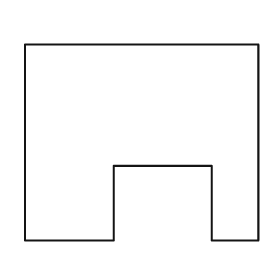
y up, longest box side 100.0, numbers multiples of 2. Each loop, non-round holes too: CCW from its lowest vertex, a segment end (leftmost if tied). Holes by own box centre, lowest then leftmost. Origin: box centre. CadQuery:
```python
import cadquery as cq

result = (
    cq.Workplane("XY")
    .moveTo(-50.0, -42.0)
    .lineTo(-12.0, -42.0)
    .lineTo(-12.0, -10.0)
    .lineTo(30.0, -10.0)
    .lineTo(30.0, -42.0)
    .lineTo(50.0, -42.0)
    .lineTo(50.0, 42.0)
    .lineTo(-50.0, 42.0)
    .close()
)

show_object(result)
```